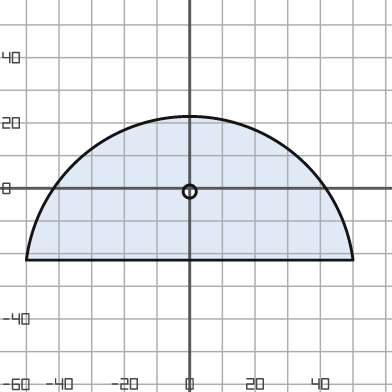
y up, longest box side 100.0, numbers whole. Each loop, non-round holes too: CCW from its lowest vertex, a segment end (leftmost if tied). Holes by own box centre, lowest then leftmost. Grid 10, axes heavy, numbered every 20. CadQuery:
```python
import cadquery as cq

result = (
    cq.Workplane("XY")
    .moveTo(-50.0, -22.0)
    .lineTo(50.0, -22.0)
    .threePointArc((0.0, 22.0), (-50.0, -22.0))
    .close()
    .moveTo(0.0, -1.0)
    .circle(2.0)
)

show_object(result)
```